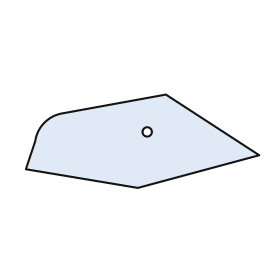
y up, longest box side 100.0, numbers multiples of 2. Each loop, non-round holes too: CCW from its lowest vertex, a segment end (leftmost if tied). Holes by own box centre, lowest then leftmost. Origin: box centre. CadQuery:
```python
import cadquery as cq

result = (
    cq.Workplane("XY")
    .moveTo(-2.0, -20.0)
    .lineTo(50.0, -6.0)
    .lineTo(10.0, 20.0)
    .lineTo(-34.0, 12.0)
    .threePointArc((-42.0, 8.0), (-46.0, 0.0))
    .lineTo(-50.0, -12.0)
    .close()
    .moveTo(2.0, 4.0)
    .circle(2.0)
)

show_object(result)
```